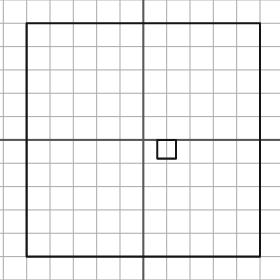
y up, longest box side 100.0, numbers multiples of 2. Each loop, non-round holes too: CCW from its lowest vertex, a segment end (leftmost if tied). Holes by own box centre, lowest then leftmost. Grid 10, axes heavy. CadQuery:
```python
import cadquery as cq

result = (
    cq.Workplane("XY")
    .moveTo(-50.0, -50.0)
    .lineTo(50.0, -50.0)
    .lineTo(50.0, 50.0)
    .lineTo(-50.0, 50.0)
    .close()
    .moveTo(6.0, -8.0)
    .lineTo(14.0, -8.0)
    .lineTo(14.0, 0.0)
    .lineTo(6.0, 0.0)
    .close()
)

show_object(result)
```